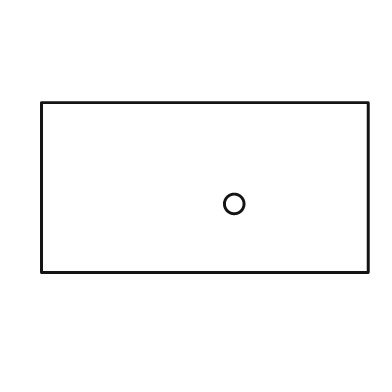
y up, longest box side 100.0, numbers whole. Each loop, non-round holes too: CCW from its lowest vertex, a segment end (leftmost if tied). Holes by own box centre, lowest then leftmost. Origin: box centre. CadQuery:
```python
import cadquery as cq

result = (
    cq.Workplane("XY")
    .moveTo(-50.0, -26.0)
    .lineTo(50.0, -26.0)
    .lineTo(50.0, 26.0)
    .lineTo(-50.0, 26.0)
    .close()
    .moveTo(9.0, -5.0)
    .circle(3.0)
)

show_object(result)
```